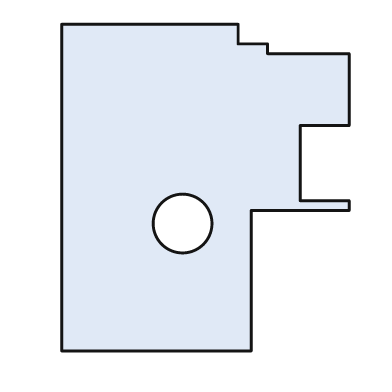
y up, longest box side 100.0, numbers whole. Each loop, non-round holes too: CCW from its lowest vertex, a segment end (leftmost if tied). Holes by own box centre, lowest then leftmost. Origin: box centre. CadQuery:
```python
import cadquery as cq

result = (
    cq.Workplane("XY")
    .moveTo(-44.0, -50.0)
    .lineTo(14.0, -50.0)
    .lineTo(14.0, -7.0)
    .lineTo(44.0, -7.0)
    .lineTo(44.0, -4.0)
    .lineTo(29.0, -4.0)
    .lineTo(29.0, 19.0)
    .lineTo(44.0, 19.0)
    .lineTo(44.0, 41.0)
    .lineTo(19.0, 41.0)
    .lineTo(19.0, 44.0)
    .lineTo(10.0, 44.0)
    .lineTo(10.0, 50.0)
    .lineTo(-44.0, 50.0)
    .close()
    .moveTo(-7.0, -11.0)
    .circle(9.0)
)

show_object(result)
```